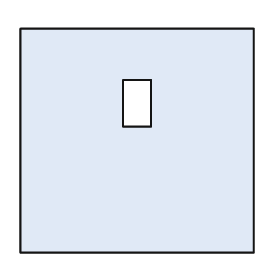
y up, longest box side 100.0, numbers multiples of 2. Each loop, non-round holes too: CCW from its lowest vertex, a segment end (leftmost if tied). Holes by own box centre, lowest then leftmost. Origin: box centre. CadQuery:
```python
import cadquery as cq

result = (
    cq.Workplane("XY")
    .moveTo(-50.0, -48.0)
    .lineTo(50.0, -48.0)
    .lineTo(50.0, 48.0)
    .lineTo(-50.0, 48.0)
    .close()
    .moveTo(-6.0, 6.0)
    .lineTo(6.0, 6.0)
    .lineTo(6.0, 26.0)
    .lineTo(-6.0, 26.0)
    .close()
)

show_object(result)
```